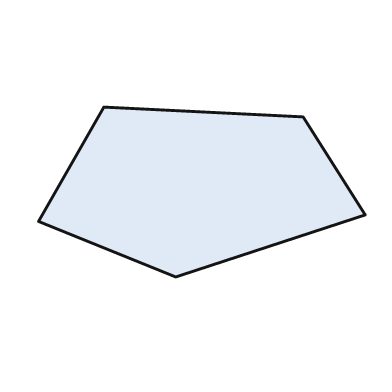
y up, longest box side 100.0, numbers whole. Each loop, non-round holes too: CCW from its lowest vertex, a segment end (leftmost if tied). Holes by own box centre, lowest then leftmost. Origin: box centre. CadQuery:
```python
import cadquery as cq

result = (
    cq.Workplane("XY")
    .moveTo(-8.0, -26.0)
    .lineTo(50.0, -7.0)
    .lineTo(31.0, 23.0)
    .lineTo(-30.0, 26.0)
    .lineTo(-50.0, -9.0)
    .close()
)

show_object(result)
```